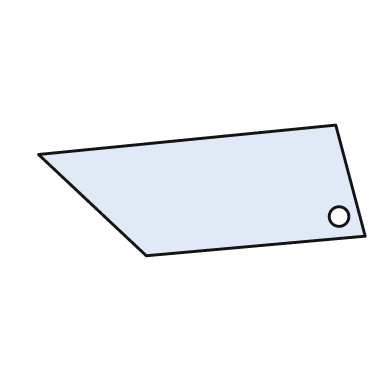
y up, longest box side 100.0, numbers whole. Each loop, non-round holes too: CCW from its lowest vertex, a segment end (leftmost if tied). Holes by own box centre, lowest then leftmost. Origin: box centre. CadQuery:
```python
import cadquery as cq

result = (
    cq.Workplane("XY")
    .moveTo(-17.0, -20.0)
    .lineTo(50.0, -14.0)
    .lineTo(41.0, 20.0)
    .lineTo(-50.0, 11.0)
    .close()
    .moveTo(42.0, -8.0)
    .circle(3.0)
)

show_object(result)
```